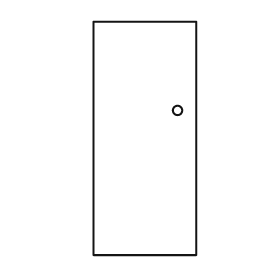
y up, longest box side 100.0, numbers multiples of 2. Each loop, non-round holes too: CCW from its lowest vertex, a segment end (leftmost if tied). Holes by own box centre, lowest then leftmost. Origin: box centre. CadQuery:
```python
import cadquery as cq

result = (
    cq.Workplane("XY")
    .moveTo(-22.0, -50.0)
    .lineTo(22.0, -50.0)
    .lineTo(22.0, 50.0)
    .lineTo(-22.0, 50.0)
    .close()
    .moveTo(14.0, 12.0)
    .circle(2.0)
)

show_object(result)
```